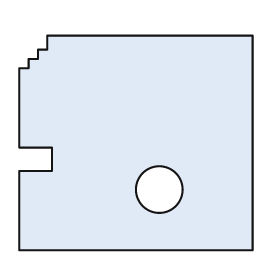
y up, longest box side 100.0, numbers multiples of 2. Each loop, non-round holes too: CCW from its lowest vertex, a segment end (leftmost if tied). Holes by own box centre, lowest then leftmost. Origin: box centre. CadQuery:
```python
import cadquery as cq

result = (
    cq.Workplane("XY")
    .moveTo(-50.0, -46.0)
    .lineTo(50.0, -46.0)
    .lineTo(50.0, 46.0)
    .lineTo(-38.0, 46.0)
    .lineTo(-38.0, 40.0)
    .lineTo(-42.0, 40.0)
    .lineTo(-42.0, 36.0)
    .lineTo(-46.0, 36.0)
    .lineTo(-46.0, 32.0)
    .lineTo(-50.0, 32.0)
    .lineTo(-50.0, -2.0)
    .lineTo(-36.0, -2.0)
    .lineTo(-36.0, -12.0)
    .lineTo(-50.0, -12.0)
    .close()
    .moveTo(10.0, -20.0)
    .circle(10.0)
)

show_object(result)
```